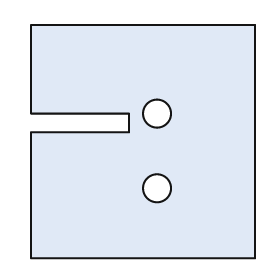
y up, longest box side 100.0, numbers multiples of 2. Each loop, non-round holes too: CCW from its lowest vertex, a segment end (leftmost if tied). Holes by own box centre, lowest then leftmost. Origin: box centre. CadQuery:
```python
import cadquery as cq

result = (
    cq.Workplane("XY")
    .moveTo(-48.0, -50.0)
    .lineTo(48.0, -50.0)
    .lineTo(48.0, 50.0)
    .lineTo(-48.0, 50.0)
    .lineTo(-48.0, 12.0)
    .lineTo(-6.0, 12.0)
    .lineTo(-6.0, 4.0)
    .lineTo(-48.0, 4.0)
    .close()
    .moveTo(6.0, -20.0)
    .circle(6.0)
    .moveTo(6.0, 12.0)
    .circle(6.0)
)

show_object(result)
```